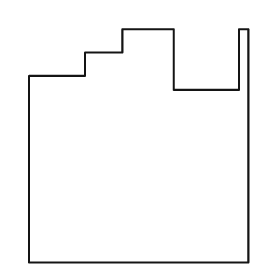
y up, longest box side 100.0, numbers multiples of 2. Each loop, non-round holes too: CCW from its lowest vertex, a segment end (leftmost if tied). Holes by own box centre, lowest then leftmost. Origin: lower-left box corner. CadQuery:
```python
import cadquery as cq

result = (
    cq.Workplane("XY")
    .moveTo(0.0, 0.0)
    .lineTo(94.0, 0.0)
    .lineTo(94.0, 100.0)
    .lineTo(90.0, 100.0)
    .lineTo(90.0, 74.0)
    .lineTo(62.0, 74.0)
    .lineTo(62.0, 100.0)
    .lineTo(40.0, 100.0)
    .lineTo(40.0, 90.0)
    .lineTo(24.0, 90.0)
    .lineTo(24.0, 80.0)
    .lineTo(0.0, 80.0)
    .close()
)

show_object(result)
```